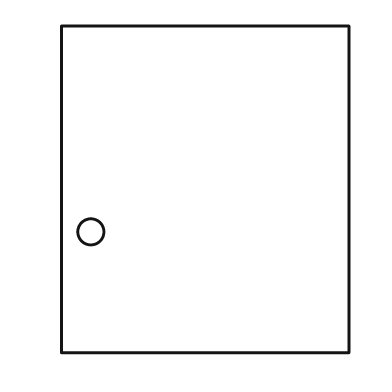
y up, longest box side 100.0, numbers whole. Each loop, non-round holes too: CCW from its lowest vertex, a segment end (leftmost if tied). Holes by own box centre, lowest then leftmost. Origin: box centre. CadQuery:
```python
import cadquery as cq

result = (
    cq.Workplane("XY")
    .moveTo(-44.0, -50.0)
    .lineTo(44.0, -50.0)
    .lineTo(44.0, 50.0)
    .lineTo(-44.0, 50.0)
    .close()
    .moveTo(-35.0, -13.0)
    .circle(4.0)
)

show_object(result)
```